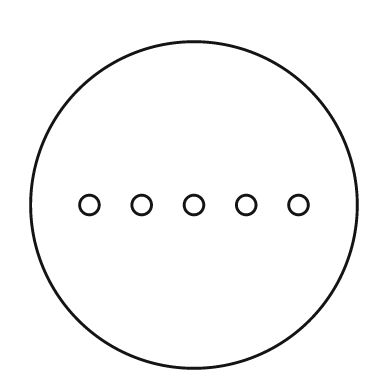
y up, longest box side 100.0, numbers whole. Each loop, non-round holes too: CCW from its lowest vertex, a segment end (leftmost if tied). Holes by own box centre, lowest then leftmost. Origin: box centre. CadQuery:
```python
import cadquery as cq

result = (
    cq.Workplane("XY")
    .moveTo(0.0, 0.0)
    .circle(50.0)
    .moveTo(-32.0, 0.0)
    .circle(3.0)
    .moveTo(-16.0, 0.0)
    .circle(3.0)
    .moveTo(0.0, 0.0)
    .circle(3.0)
    .moveTo(16.0, 0.0)
    .circle(3.0)
    .moveTo(32.0, 0.0)
    .circle(3.0)
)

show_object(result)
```